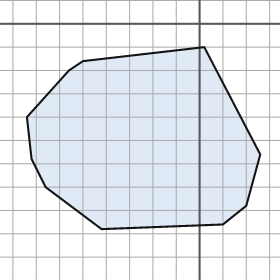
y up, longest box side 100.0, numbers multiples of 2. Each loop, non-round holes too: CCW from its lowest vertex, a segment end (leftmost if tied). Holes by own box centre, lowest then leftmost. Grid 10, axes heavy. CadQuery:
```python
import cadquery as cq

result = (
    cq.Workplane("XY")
    .moveTo(-42.0, -88.0)
    .lineTo(10.0, -86.0)
    .lineTo(20.0, -78.0)
    .lineTo(26.0, -56.0)
    .lineTo(2.0, -10.0)
    .lineTo(-50.0, -16.0)
    .lineTo(-56.0, -20.0)
    .lineTo(-74.0, -40.0)
    .lineTo(-72.0, -58.0)
    .lineTo(-66.0, -70.0)
    .close()
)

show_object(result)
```